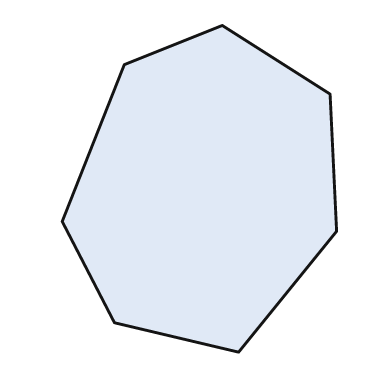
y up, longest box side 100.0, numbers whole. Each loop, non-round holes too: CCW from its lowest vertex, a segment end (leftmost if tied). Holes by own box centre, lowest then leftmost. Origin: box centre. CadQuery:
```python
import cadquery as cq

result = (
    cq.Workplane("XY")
    .moveTo(12.0, -50.0)
    .lineTo(42.0, -13.0)
    .lineTo(40.0, 29.0)
    .lineTo(7.0, 50.0)
    .lineTo(-23.0, 38.0)
    .lineTo(-42.0, -10.0)
    .lineTo(-26.0, -41.0)
    .close()
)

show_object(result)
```